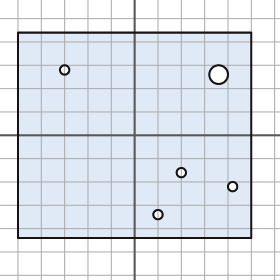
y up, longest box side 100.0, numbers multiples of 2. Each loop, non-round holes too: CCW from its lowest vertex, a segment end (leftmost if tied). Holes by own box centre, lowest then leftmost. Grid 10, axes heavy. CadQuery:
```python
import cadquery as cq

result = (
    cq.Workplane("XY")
    .moveTo(-50.0, -44.0)
    .lineTo(50.0, -44.0)
    .lineTo(50.0, 44.0)
    .lineTo(-50.0, 44.0)
    .close()
    .moveTo(10.0, -34.0)
    .circle(2.0)
    .moveTo(42.0, -22.0)
    .circle(2.0)
    .moveTo(20.0, -16.0)
    .circle(2.0)
    .moveTo(36.0, 26.0)
    .circle(4.0)
    .moveTo(-30.0, 28.0)
    .circle(2.0)
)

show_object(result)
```